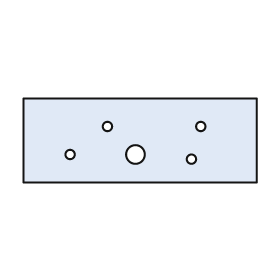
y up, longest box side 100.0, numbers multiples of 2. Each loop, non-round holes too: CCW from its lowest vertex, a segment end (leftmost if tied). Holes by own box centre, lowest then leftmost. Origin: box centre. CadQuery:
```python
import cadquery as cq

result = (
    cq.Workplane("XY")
    .moveTo(-50.0, -18.0)
    .lineTo(50.0, -18.0)
    .lineTo(50.0, 18.0)
    .lineTo(-50.0, 18.0)
    .close()
    .moveTo(22.0, -8.0)
    .circle(2.0)
    .moveTo(-30.0, -6.0)
    .circle(2.0)
    .moveTo(-2.0, -6.0)
    .circle(4.0)
    .moveTo(-14.0, 6.0)
    .circle(2.0)
    .moveTo(26.0, 6.0)
    .circle(2.0)
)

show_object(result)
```